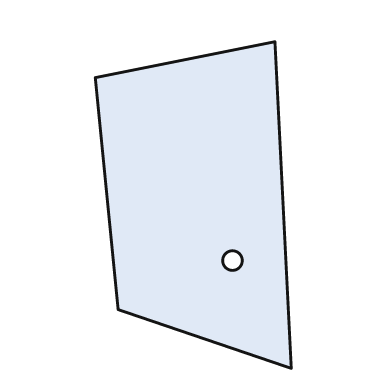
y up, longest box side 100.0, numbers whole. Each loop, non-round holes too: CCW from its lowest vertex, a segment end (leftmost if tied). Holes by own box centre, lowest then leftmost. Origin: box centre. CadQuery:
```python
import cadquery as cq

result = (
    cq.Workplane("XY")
    .moveTo(30.0, -50.0)
    .lineTo(25.0, 50.0)
    .lineTo(-30.0, 39.0)
    .lineTo(-23.0, -32.0)
    .close()
    .moveTo(12.0, -17.0)
    .circle(3.0)
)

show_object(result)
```